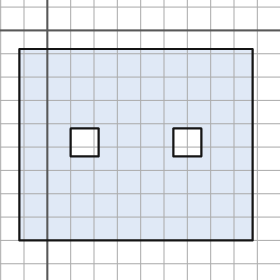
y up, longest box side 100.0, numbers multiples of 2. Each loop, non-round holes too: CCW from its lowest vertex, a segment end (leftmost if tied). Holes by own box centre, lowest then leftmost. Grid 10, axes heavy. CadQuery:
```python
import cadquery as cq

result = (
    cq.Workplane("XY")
    .moveTo(-12.0, -90.0)
    .lineTo(88.0, -90.0)
    .lineTo(88.0, -8.0)
    .lineTo(-12.0, -8.0)
    .close()
    .moveTo(10.0, -54.0)
    .lineTo(22.0, -54.0)
    .lineTo(22.0, -42.0)
    .lineTo(10.0, -42.0)
    .close()
    .moveTo(54.0, -54.0)
    .lineTo(66.0, -54.0)
    .lineTo(66.0, -42.0)
    .lineTo(54.0, -42.0)
    .close()
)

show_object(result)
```